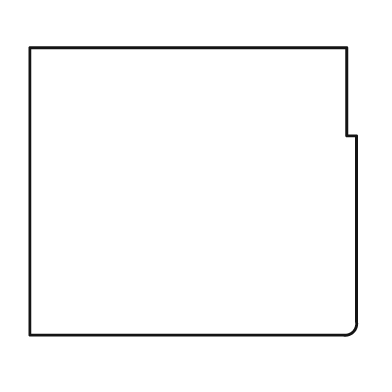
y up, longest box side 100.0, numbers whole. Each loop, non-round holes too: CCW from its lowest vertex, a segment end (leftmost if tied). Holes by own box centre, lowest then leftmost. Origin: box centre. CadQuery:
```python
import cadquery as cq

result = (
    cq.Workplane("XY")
    .moveTo(-50.0, -44.0)
    .lineTo(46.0, -44.0)
    .threePointArc((49.0, -43.0), (50.0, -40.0))
    .lineTo(50.0, 17.0)
    .lineTo(47.0, 17.0)
    .lineTo(47.0, 44.0)
    .lineTo(-50.0, 44.0)
    .close()
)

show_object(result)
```